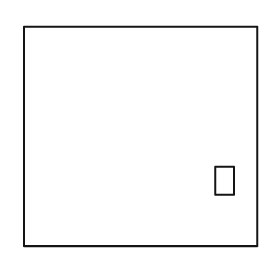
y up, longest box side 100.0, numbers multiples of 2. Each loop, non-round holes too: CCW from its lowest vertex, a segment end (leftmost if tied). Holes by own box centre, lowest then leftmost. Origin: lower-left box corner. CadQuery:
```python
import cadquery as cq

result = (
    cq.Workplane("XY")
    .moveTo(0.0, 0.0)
    .lineTo(100.0, 0.0)
    .lineTo(100.0, 94.0)
    .lineTo(0.0, 94.0)
    .close()
    .moveTo(82.0, 22.0)
    .lineTo(90.0, 22.0)
    .lineTo(90.0, 34.0)
    .lineTo(82.0, 34.0)
    .close()
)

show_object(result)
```